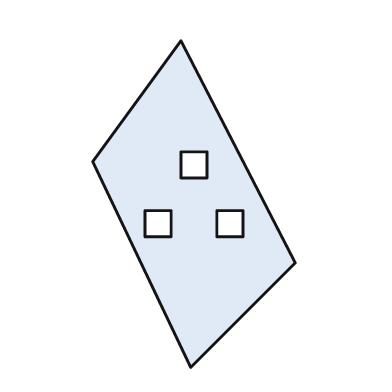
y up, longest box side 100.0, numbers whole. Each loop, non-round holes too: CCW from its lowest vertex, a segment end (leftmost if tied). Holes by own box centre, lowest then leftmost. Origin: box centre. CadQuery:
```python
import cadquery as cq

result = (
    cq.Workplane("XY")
    .moveTo(-1.0, -50.0)
    .lineTo(31.0, -18.0)
    .lineTo(-4.0, 50.0)
    .lineTo(-31.0, 13.0)
    .close()
    .moveTo(-15.0, -10.0)
    .lineTo(-7.0, -10.0)
    .lineTo(-7.0, -2.0)
    .lineTo(-15.0, -2.0)
    .close()
    .moveTo(7.0, -10.0)
    .lineTo(15.0, -10.0)
    .lineTo(15.0, -2.0)
    .lineTo(7.0, -2.0)
    .close()
    .moveTo(-4.0, 8.0)
    .lineTo(4.0, 8.0)
    .lineTo(4.0, 16.0)
    .lineTo(-4.0, 16.0)
    .close()
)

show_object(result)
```